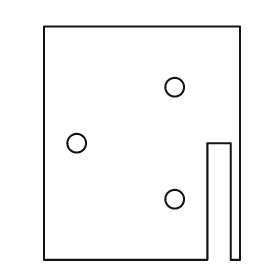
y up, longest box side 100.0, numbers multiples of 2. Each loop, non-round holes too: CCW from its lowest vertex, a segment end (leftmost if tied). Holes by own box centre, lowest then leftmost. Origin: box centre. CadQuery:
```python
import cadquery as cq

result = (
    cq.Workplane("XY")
    .moveTo(-42.0, -50.0)
    .lineTo(28.0, -50.0)
    .lineTo(28.0, 0.0)
    .lineTo(38.0, 0.0)
    .lineTo(38.0, -50.0)
    .lineTo(42.0, -50.0)
    .lineTo(42.0, 50.0)
    .lineTo(-42.0, 50.0)
    .close()
    .moveTo(14.0, -24.0)
    .circle(4.0)
    .moveTo(-28.0, 0.0)
    .circle(4.0)
    .moveTo(14.0, 24.0)
    .circle(4.0)
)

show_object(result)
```